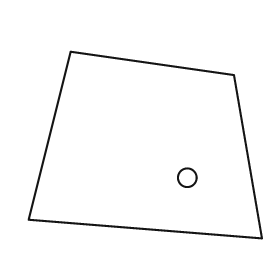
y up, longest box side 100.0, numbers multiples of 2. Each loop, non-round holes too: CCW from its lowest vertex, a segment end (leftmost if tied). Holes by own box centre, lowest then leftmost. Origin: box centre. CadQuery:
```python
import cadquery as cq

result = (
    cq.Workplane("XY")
    .moveTo(50.0, -40.0)
    .lineTo(38.0, 30.0)
    .lineTo(-32.0, 40.0)
    .lineTo(-50.0, -32.0)
    .close()
    .moveTo(18.0, -14.0)
    .circle(4.0)
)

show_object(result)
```